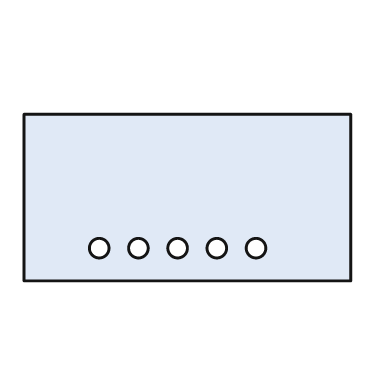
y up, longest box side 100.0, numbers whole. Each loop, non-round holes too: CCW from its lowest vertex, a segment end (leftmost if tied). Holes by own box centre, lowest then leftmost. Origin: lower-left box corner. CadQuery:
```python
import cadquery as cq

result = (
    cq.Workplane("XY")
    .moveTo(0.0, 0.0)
    .lineTo(100.0, 0.0)
    .lineTo(100.0, 51.0)
    .lineTo(0.0, 51.0)
    .close()
    .moveTo(23.0, 10.0)
    .circle(3.0)
    .moveTo(35.0, 10.0)
    .circle(3.0)
    .moveTo(47.0, 10.0)
    .circle(3.0)
    .moveTo(59.0, 10.0)
    .circle(3.0)
    .moveTo(71.0, 10.0)
    .circle(3.0)
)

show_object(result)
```